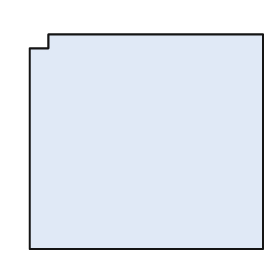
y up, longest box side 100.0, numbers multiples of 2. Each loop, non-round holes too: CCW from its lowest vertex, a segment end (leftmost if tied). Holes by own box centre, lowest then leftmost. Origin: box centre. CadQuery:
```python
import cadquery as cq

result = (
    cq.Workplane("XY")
    .moveTo(-50.0, -46.0)
    .lineTo(50.0, -46.0)
    .lineTo(50.0, 46.0)
    .lineTo(-42.0, 46.0)
    .lineTo(-42.0, 40.0)
    .lineTo(-50.0, 40.0)
    .close()
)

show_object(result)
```